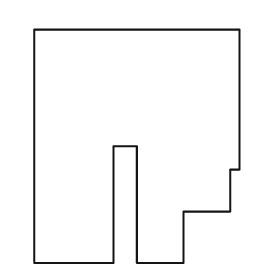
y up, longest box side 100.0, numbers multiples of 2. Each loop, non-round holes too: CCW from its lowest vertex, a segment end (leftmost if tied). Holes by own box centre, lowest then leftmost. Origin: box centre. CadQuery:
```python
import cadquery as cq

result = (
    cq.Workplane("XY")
    .moveTo(-44.0, -50.0)
    .lineTo(-10.0, -50.0)
    .lineTo(-10.0, 0.0)
    .lineTo(0.0, 0.0)
    .lineTo(0.0, -50.0)
    .lineTo(20.0, -50.0)
    .lineTo(20.0, -28.0)
    .lineTo(40.0, -28.0)
    .lineTo(40.0, -10.0)
    .lineTo(44.0, -10.0)
    .lineTo(44.0, 50.0)
    .lineTo(-44.0, 50.0)
    .close()
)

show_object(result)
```